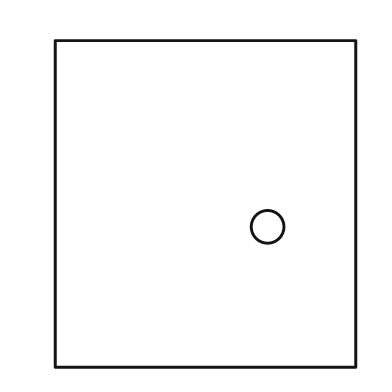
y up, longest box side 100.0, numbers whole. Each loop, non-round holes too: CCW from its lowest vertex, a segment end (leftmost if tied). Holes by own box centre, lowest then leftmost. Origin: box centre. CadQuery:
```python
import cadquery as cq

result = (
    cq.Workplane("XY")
    .moveTo(-46.0, -50.0)
    .lineTo(46.0, -50.0)
    .lineTo(46.0, 50.0)
    .lineTo(-46.0, 50.0)
    .close()
    .moveTo(19.0, -7.0)
    .circle(5.0)
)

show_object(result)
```